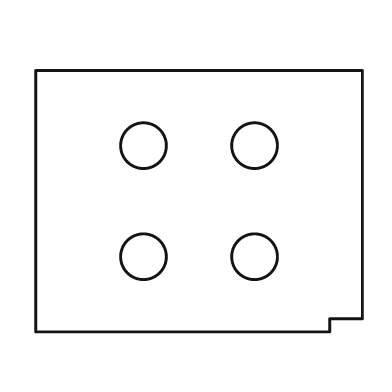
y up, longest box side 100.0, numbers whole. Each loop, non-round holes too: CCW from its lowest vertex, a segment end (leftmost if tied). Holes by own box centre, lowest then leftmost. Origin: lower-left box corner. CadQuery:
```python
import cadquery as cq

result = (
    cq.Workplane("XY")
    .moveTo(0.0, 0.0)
    .lineTo(90.0, 0.0)
    .lineTo(90.0, 4.0)
    .lineTo(100.0, 4.0)
    .lineTo(100.0, 80.0)
    .lineTo(0.0, 80.0)
    .close()
    .moveTo(33.0, 23.0)
    .circle(7.0)
    .moveTo(67.0, 23.0)
    .circle(7.0)
    .moveTo(33.0, 57.0)
    .circle(7.0)
    .moveTo(67.0, 57.0)
    .circle(7.0)
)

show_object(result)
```